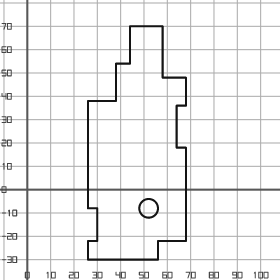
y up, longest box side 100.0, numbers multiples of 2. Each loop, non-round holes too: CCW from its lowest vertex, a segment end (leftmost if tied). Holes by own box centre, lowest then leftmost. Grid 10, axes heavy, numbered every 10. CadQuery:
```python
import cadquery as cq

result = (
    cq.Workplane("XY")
    .moveTo(26.0, -30.0)
    .lineTo(56.0, -30.0)
    .lineTo(56.0, -22.0)
    .lineTo(68.0, -22.0)
    .lineTo(68.0, 18.0)
    .lineTo(64.0, 18.0)
    .lineTo(64.0, 36.0)
    .lineTo(68.0, 36.0)
    .lineTo(68.0, 48.0)
    .lineTo(58.0, 48.0)
    .lineTo(58.0, 70.0)
    .lineTo(44.0, 70.0)
    .lineTo(44.0, 54.0)
    .lineTo(38.0, 54.0)
    .lineTo(38.0, 38.0)
    .lineTo(26.0, 38.0)
    .lineTo(26.0, -8.0)
    .lineTo(30.0, -8.0)
    .lineTo(30.0, -22.0)
    .lineTo(26.0, -22.0)
    .close()
    .moveTo(52.0, -8.0)
    .circle(4.0)
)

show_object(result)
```